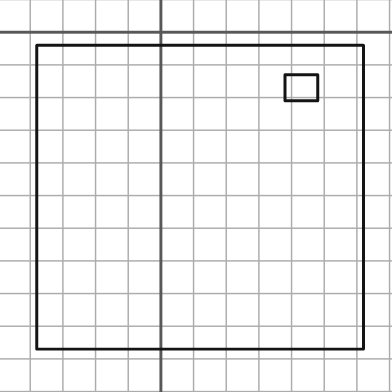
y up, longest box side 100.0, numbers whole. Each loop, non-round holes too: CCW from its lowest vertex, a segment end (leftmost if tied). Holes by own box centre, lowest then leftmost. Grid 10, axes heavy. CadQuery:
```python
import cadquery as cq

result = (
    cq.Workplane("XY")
    .moveTo(-38.0, -97.0)
    .lineTo(62.0, -97.0)
    .lineTo(62.0, -4.0)
    .lineTo(-38.0, -4.0)
    .close()
    .moveTo(38.0, -21.0)
    .lineTo(48.0, -21.0)
    .lineTo(48.0, -13.0)
    .lineTo(38.0, -13.0)
    .close()
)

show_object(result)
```